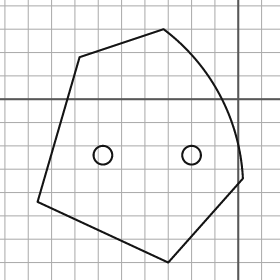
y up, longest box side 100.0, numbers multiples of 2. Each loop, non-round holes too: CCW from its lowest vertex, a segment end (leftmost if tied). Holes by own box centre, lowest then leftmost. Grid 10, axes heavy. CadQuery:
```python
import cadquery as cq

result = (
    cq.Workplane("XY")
    .moveTo(-30.0, -70.0)
    .lineTo(2.0, -34.0)
    .threePointArc((-8.0, 2.0), (-32.0, 30.0))
    .lineTo(-68.0, 18.0)
    .lineTo(-86.0, -44.0)
    .close()
    .moveTo(-58.0, -24.0)
    .circle(4.0)
    .moveTo(-20.0, -24.0)
    .circle(4.0)
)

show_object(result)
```